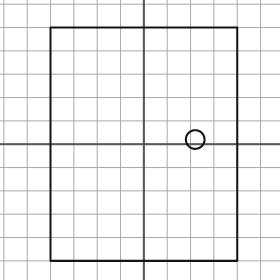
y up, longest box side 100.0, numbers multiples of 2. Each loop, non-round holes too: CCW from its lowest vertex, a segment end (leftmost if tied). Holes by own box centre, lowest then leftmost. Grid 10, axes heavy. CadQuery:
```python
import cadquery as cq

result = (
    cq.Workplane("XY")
    .moveTo(-40.0, -50.0)
    .lineTo(40.0, -50.0)
    .lineTo(40.0, 50.0)
    .lineTo(-40.0, 50.0)
    .close()
    .moveTo(22.0, 2.0)
    .circle(4.0)
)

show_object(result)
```